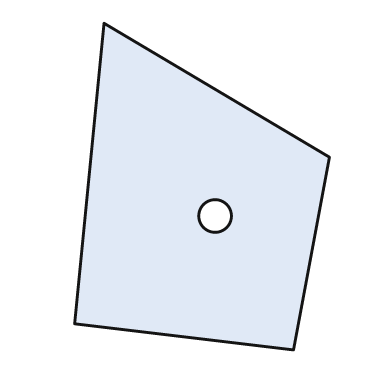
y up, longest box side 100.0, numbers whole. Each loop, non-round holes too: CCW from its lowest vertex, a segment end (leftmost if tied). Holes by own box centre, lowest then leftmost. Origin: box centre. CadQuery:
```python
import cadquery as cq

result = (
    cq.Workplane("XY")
    .moveTo(28.0, -50.0)
    .lineTo(39.0, 9.0)
    .lineTo(-30.0, 50.0)
    .lineTo(-39.0, -42.0)
    .close()
    .moveTo(4.0, -9.0)
    .circle(5.0)
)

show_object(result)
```